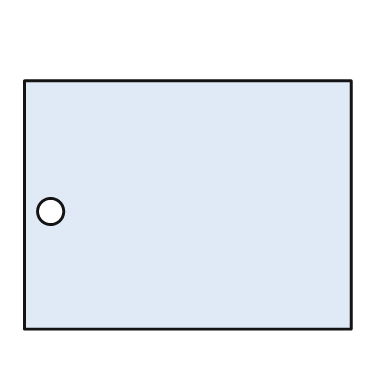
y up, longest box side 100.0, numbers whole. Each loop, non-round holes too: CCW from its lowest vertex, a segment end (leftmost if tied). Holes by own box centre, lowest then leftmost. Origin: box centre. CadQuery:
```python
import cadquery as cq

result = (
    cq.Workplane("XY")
    .moveTo(-50.0, -38.0)
    .lineTo(50.0, -38.0)
    .lineTo(50.0, 38.0)
    .lineTo(-50.0, 38.0)
    .close()
    .moveTo(-42.0, -2.0)
    .circle(4.0)
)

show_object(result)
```